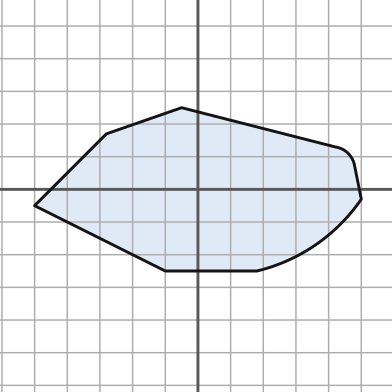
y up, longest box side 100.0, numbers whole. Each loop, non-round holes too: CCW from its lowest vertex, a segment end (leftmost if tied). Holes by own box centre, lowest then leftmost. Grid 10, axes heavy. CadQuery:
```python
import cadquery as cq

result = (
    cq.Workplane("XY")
    .moveTo(-10.0, -25.0)
    .lineTo(18.0, -25.0)
    .threePointArc((36.0, -17.0), (50.0, -3.0))
    .lineTo(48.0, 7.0)
    .threePointArc((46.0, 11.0), (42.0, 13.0))
    .lineTo(-5.0, 25.0)
    .lineTo(-28.0, 17.0)
    .lineTo(-50.0, -5.0)
    .close()
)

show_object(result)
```